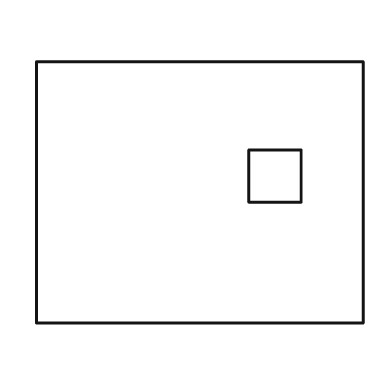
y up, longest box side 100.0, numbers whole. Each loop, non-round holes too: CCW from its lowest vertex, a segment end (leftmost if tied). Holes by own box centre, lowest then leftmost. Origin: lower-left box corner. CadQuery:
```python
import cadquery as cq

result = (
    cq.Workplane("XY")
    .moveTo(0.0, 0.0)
    .lineTo(100.0, 0.0)
    .lineTo(100.0, 80.0)
    .lineTo(0.0, 80.0)
    .close()
    .moveTo(65.0, 37.0)
    .lineTo(81.0, 37.0)
    .lineTo(81.0, 53.0)
    .lineTo(65.0, 53.0)
    .close()
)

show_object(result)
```